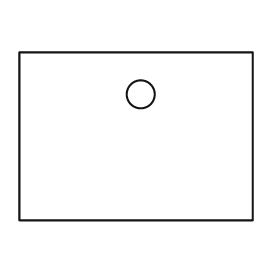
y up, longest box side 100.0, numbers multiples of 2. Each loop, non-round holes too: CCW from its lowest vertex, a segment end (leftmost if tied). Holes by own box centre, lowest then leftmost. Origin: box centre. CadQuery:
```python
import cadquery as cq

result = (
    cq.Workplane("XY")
    .moveTo(-50.0, -36.0)
    .lineTo(50.0, -36.0)
    .lineTo(50.0, 36.0)
    .lineTo(-50.0, 36.0)
    .close()
    .moveTo(2.0, 18.0)
    .circle(6.0)
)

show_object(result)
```